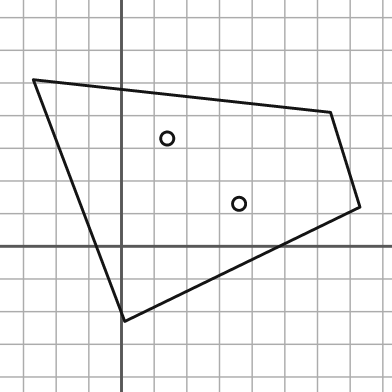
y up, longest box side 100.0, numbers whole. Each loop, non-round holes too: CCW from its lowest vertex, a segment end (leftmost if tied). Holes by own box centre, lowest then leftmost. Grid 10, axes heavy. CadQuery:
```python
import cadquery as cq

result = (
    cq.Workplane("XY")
    .moveTo(1.0, -23.0)
    .lineTo(73.0, 12.0)
    .lineTo(64.0, 41.0)
    .lineTo(-27.0, 51.0)
    .close()
    .moveTo(36.0, 13.0)
    .circle(2.0)
    .moveTo(14.0, 33.0)
    .circle(2.0)
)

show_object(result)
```